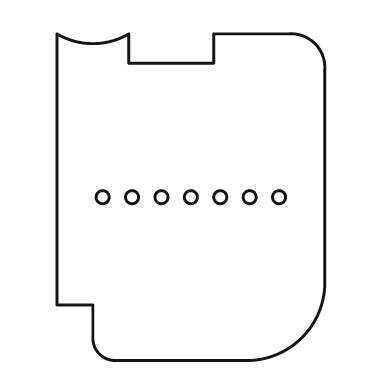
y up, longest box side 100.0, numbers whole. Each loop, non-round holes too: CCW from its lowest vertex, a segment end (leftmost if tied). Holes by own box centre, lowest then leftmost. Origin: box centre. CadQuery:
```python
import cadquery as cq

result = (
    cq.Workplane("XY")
    .moveTo(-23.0, -50.0)
    .lineTo(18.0, -50.0)
    .threePointArc((34.0, -43.0), (41.0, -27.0))
    .lineTo(41.0, 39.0)
    .threePointArc((38.0, 47.0), (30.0, 50.0))
    .lineTo(7.0, 50.0)
    .lineTo(7.0, 41.0)
    .lineTo(-19.0, 41.0)
    .lineTo(-19.0, 50.0)
    .threePointArc((-30.0, 47.0), (-41.0, 50.0))
    .lineTo(-41.0, -33.0)
    .lineTo(-30.0, -33.0)
    .lineTo(-30.0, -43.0)
    .threePointArc((-28.0, -48.0), (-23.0, -50.0))
    .close()
    .moveTo(-27.0, 0.0)
    .circle(2.0)
    .moveTo(-18.0, 0.0)
    .circle(2.0)
    .moveTo(-9.0, 0.0)
    .circle(2.0)
    .moveTo(0.0, 0.0)
    .circle(2.0)
    .moveTo(9.0, 0.0)
    .circle(2.0)
    .moveTo(18.0, 0.0)
    .circle(2.0)
    .moveTo(27.0, 0.0)
    .circle(2.0)
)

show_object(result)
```